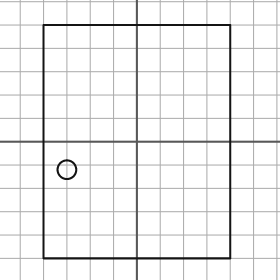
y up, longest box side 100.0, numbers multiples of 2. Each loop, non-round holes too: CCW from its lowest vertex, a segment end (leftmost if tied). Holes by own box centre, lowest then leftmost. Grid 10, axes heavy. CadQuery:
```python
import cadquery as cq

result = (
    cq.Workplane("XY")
    .moveTo(-40.0, -50.0)
    .lineTo(40.0, -50.0)
    .lineTo(40.0, 50.0)
    .lineTo(-40.0, 50.0)
    .close()
    .moveTo(-30.0, -12.0)
    .circle(4.0)
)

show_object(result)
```